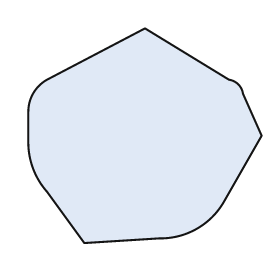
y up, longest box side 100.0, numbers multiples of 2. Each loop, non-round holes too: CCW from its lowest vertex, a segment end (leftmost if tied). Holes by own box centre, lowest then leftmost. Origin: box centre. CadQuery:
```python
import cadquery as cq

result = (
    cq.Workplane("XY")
    .moveTo(-26.0, -46.0)
    .lineTo(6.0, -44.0)
    .threePointArc((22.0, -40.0), (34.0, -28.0))
    .lineTo(50.0, 0.0)
    .lineTo(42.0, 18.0)
    .threePointArc((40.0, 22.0), (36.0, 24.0))
    .lineTo(0.0, 46.0)
    .lineTo(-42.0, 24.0)
    .threePointArc((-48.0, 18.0), (-50.0, 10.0))
    .lineTo(-50.0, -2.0)
    .threePointArc((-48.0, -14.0), (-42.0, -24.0))
    .close()
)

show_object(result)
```